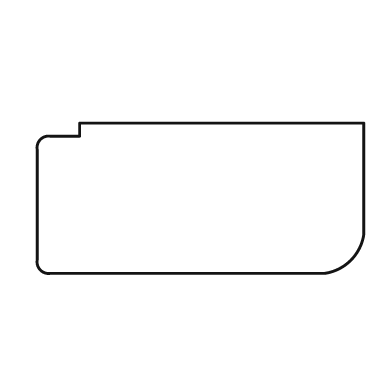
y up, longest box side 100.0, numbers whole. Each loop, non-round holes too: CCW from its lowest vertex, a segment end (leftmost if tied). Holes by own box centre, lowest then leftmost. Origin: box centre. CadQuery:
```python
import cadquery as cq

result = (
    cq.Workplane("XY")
    .moveTo(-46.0, -23.0)
    .lineTo(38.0, -23.0)
    .threePointArc((46.0, -19.0), (50.0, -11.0))
    .lineTo(50.0, 23.0)
    .lineTo(-37.0, 23.0)
    .lineTo(-37.0, 19.0)
    .lineTo(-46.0, 19.0)
    .threePointArc((-49.0, 18.0), (-50.0, 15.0))
    .lineTo(-50.0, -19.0)
    .threePointArc((-49.0, -22.0), (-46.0, -23.0))
    .close()
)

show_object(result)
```